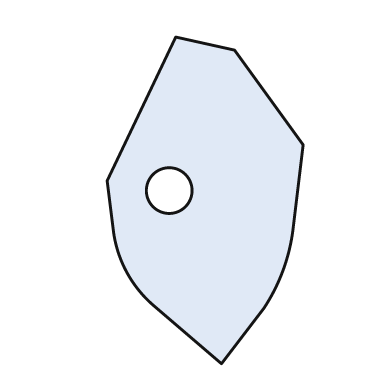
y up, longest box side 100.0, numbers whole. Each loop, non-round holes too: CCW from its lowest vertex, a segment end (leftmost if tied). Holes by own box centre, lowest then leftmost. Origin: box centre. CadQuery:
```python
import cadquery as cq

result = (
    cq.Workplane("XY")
    .moveTo(5.0, -50.0)
    .lineTo(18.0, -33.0)
    .threePointArc((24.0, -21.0), (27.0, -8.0))
    .lineTo(30.0, 17.0)
    .lineTo(9.0, 46.0)
    .lineTo(-9.0, 50.0)
    .lineTo(-30.0, 6.0)
    .lineTo(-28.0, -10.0)
    .threePointArc((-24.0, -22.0), (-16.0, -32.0))
    .close()
    .moveTo(-11.0, 3.0)
    .circle(7.0)
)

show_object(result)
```